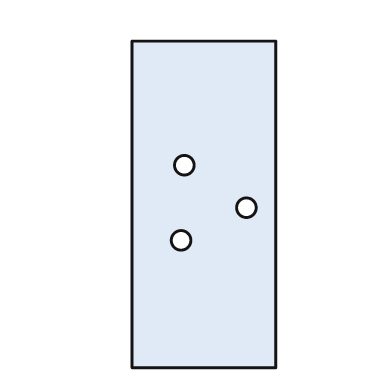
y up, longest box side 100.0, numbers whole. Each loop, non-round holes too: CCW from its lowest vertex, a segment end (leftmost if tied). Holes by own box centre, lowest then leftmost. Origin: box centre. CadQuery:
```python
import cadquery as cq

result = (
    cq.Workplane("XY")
    .moveTo(-22.0, -50.0)
    .lineTo(22.0, -50.0)
    .lineTo(22.0, 50.0)
    .lineTo(-22.0, 50.0)
    .close()
    .moveTo(-7.0, -11.0)
    .circle(3.0)
    .moveTo(13.0, -1.0)
    .circle(3.0)
    .moveTo(-6.0, 12.0)
    .circle(3.0)
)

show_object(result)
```